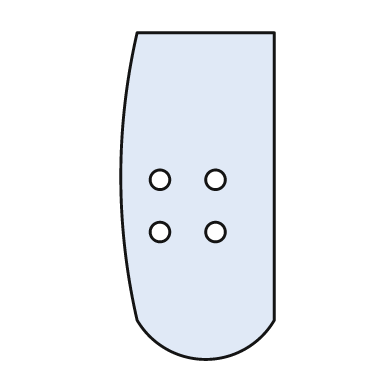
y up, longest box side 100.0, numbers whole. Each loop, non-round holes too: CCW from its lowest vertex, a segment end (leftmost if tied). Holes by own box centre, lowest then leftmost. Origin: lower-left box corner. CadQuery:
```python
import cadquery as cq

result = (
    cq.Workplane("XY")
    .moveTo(5.0, 12.0)
    .threePointArc((26.0, 0.0), (47.0, 12.0))
    .lineTo(47.0, 100.0)
    .lineTo(5.0, 100.0)
    .threePointArc((0.0, 56.0), (5.0, 12.0))
    .close()
    .moveTo(12.0, 39.0)
    .circle(3.0)
    .moveTo(29.0, 39.0)
    .circle(3.0)
    .moveTo(12.0, 55.0)
    .circle(3.0)
    .moveTo(29.0, 55.0)
    .circle(3.0)
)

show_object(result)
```